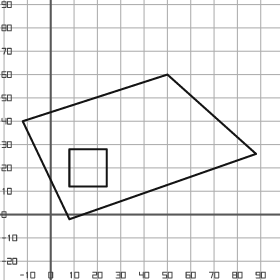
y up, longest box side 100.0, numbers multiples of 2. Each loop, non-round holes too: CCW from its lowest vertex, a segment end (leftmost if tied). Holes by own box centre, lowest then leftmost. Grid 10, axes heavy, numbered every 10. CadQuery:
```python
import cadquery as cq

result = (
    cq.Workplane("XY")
    .moveTo(8.0, -2.0)
    .lineTo(88.0, 26.0)
    .lineTo(50.0, 60.0)
    .lineTo(-12.0, 40.0)
    .close()
    .moveTo(8.0, 12.0)
    .lineTo(24.0, 12.0)
    .lineTo(24.0, 28.0)
    .lineTo(8.0, 28.0)
    .close()
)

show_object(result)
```